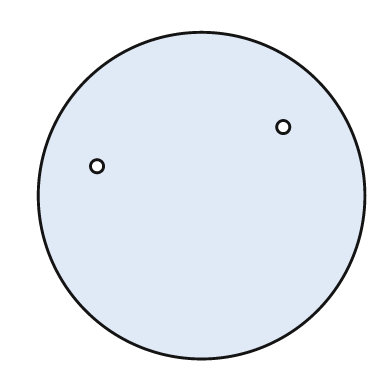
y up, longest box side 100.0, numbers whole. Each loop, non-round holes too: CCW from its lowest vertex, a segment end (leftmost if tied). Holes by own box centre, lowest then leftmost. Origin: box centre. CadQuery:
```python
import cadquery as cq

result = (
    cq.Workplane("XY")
    .moveTo(0.0, 0.0)
    .circle(50.0)
    .moveTo(-32.0, 9.0)
    .circle(2.0)
    .moveTo(25.0, 21.0)
    .circle(2.0)
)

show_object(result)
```